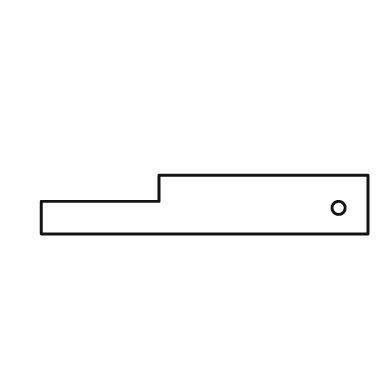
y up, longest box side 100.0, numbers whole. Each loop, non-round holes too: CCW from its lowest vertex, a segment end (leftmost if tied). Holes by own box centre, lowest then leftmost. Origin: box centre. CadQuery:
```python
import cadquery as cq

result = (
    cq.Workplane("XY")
    .moveTo(-50.0, -9.0)
    .lineTo(50.0, -9.0)
    .lineTo(50.0, 9.0)
    .lineTo(-14.0, 9.0)
    .lineTo(-14.0, 1.0)
    .lineTo(-50.0, 1.0)
    .close()
    .moveTo(41.0, -1.0)
    .circle(2.0)
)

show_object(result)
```